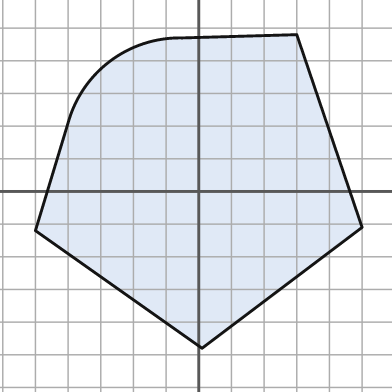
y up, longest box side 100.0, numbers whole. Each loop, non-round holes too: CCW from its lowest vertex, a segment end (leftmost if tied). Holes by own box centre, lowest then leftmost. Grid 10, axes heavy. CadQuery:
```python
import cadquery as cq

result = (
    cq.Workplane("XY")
    .moveTo(1.0, -48.0)
    .lineTo(50.0, -11.0)
    .lineTo(30.0, 48.0)
    .lineTo(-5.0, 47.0)
    .threePointArc((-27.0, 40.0), (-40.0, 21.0))
    .lineTo(-50.0, -12.0)
    .close()
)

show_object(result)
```